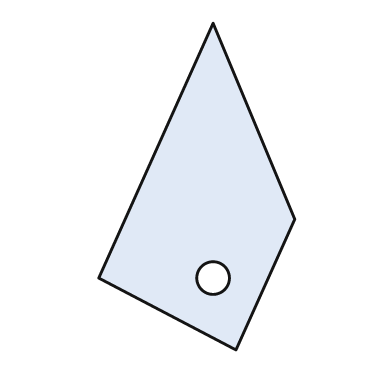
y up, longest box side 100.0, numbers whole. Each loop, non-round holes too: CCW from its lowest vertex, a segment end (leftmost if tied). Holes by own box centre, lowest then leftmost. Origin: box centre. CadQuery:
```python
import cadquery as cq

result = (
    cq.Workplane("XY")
    .moveTo(12.0, -50.0)
    .lineTo(30.0, -10.0)
    .lineTo(5.0, 50.0)
    .lineTo(-30.0, -28.0)
    .close()
    .moveTo(5.0, -28.0)
    .circle(5.0)
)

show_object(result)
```